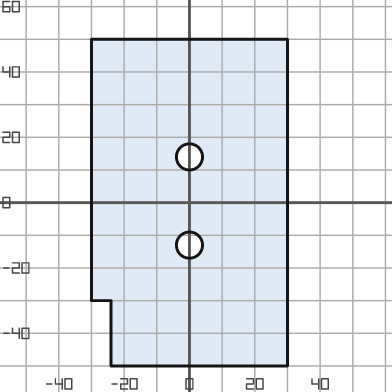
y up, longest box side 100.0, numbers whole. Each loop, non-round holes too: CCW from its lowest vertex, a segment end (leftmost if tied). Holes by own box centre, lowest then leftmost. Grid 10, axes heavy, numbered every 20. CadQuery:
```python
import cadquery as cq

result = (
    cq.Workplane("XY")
    .moveTo(-24.0, -50.0)
    .lineTo(30.0, -50.0)
    .lineTo(30.0, 50.0)
    .lineTo(-30.0, 50.0)
    .lineTo(-30.0, -30.0)
    .lineTo(-24.0, -30.0)
    .close()
    .moveTo(0.0, -13.0)
    .circle(4.0)
    .moveTo(0.0, 14.0)
    .circle(4.0)
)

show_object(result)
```